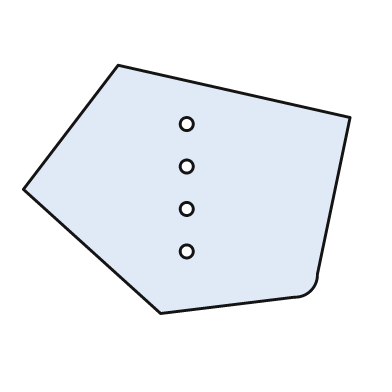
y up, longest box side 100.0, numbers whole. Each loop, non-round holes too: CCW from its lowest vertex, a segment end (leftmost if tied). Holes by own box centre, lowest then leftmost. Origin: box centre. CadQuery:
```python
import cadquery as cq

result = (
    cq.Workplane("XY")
    .moveTo(-8.0, -38.0)
    .lineTo(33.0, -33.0)
    .threePointArc((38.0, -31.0), (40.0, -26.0))
    .lineTo(50.0, 22.0)
    .lineTo(-21.0, 38.0)
    .lineTo(-50.0, 0.0)
    .close()
    .moveTo(0.0, -19.0)
    .circle(2.0)
    .moveTo(0.0, -6.0)
    .circle(2.0)
    .moveTo(0.0, 7.0)
    .circle(2.0)
    .moveTo(0.0, 20.0)
    .circle(2.0)
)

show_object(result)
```